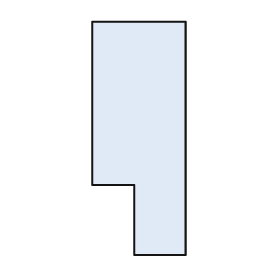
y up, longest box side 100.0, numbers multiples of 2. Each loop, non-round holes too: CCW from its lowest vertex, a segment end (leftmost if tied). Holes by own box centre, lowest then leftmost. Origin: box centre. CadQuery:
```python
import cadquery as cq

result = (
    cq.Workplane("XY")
    .moveTo(-2.0, -50.0)
    .lineTo(20.0, -50.0)
    .lineTo(20.0, 50.0)
    .lineTo(-20.0, 50.0)
    .lineTo(-20.0, -20.0)
    .lineTo(-2.0, -20.0)
    .close()
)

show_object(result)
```